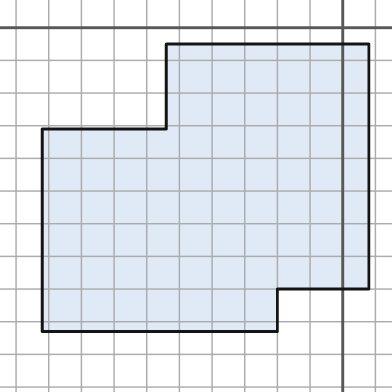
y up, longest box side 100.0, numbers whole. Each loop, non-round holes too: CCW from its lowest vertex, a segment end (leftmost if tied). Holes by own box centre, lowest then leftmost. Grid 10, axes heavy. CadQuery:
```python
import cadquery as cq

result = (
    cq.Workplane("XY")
    .moveTo(-92.0, -93.0)
    .lineTo(-20.0, -93.0)
    .lineTo(-20.0, -80.0)
    .lineTo(8.0, -80.0)
    .lineTo(8.0, -5.0)
    .lineTo(-54.0, -5.0)
    .lineTo(-54.0, -31.0)
    .lineTo(-92.0, -31.0)
    .close()
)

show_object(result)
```